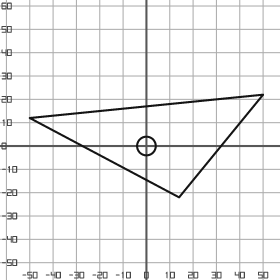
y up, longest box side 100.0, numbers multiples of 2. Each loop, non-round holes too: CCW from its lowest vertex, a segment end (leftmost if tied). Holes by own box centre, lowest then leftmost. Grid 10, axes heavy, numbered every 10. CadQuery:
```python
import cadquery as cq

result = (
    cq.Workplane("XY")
    .moveTo(14.0, -22.0)
    .lineTo(50.0, 22.0)
    .lineTo(-50.0, 12.0)
    .close()
    .moveTo(0.0, 0.0)
    .circle(4.0)
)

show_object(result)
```